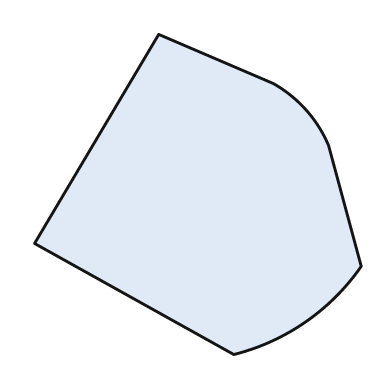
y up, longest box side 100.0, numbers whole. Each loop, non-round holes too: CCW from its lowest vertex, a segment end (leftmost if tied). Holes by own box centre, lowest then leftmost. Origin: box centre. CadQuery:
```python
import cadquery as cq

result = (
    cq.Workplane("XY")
    .moveTo(11.0, -49.0)
    .threePointArc((33.0, -39.0), (50.0, -22.0))
    .lineTo(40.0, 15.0)
    .threePointArc((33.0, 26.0), (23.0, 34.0))
    .lineTo(-12.0, 49.0)
    .lineTo(-50.0, -15.0)
    .close()
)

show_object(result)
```